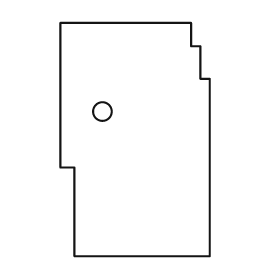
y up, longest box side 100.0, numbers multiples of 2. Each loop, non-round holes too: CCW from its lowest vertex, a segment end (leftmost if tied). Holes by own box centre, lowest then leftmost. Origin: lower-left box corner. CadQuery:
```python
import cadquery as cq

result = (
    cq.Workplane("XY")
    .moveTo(6.0, 0.0)
    .lineTo(64.0, 0.0)
    .lineTo(64.0, 76.0)
    .lineTo(60.0, 76.0)
    .lineTo(60.0, 90.0)
    .lineTo(56.0, 90.0)
    .lineTo(56.0, 100.0)
    .lineTo(0.0, 100.0)
    .lineTo(0.0, 38.0)
    .lineTo(6.0, 38.0)
    .close()
    .moveTo(18.0, 62.0)
    .circle(4.0)
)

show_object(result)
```